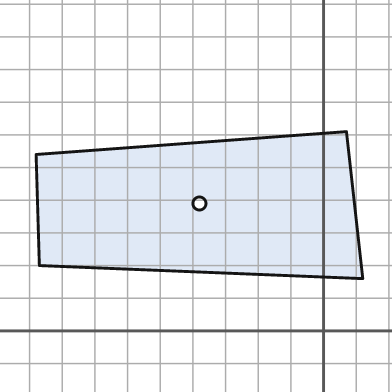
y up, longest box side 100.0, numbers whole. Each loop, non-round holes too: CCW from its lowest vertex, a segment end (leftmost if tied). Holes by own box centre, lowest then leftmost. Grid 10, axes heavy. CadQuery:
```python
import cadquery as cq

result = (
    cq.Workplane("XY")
    .moveTo(12.0, 16.0)
    .lineTo(7.0, 61.0)
    .lineTo(-88.0, 54.0)
    .lineTo(-87.0, 20.0)
    .close()
    .moveTo(-38.0, 39.0)
    .circle(2.0)
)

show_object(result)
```